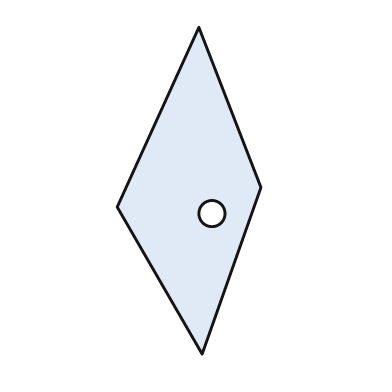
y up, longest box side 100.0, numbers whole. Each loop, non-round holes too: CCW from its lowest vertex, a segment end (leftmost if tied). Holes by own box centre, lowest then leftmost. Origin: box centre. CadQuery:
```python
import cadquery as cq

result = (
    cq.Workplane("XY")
    .moveTo(4.0, -50.0)
    .lineTo(22.0, 1.0)
    .lineTo(3.0, 50.0)
    .lineTo(-22.0, -5.0)
    .close()
    .moveTo(7.0, -7.0)
    .circle(4.0)
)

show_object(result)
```